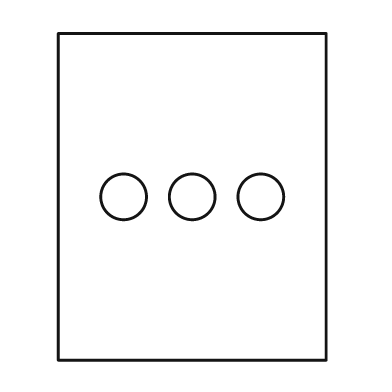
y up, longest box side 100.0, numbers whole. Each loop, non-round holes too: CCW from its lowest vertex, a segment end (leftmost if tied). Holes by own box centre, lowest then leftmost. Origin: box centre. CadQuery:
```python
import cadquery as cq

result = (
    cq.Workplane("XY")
    .moveTo(-41.0, -50.0)
    .lineTo(41.0, -50.0)
    .lineTo(41.0, 50.0)
    .lineTo(-41.0, 50.0)
    .close()
    .moveTo(-21.0, 0.0)
    .circle(7.0)
    .moveTo(0.0, 0.0)
    .circle(7.0)
    .moveTo(21.0, 0.0)
    .circle(7.0)
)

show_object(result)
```